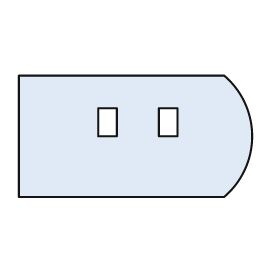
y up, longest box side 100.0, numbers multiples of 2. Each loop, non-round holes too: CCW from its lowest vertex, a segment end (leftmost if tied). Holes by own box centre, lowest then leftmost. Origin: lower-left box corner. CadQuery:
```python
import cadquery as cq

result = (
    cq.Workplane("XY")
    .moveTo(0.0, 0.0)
    .lineTo(88.0, 0.0)
    .threePointArc((100.0, 26.0), (88.0, 52.0))
    .lineTo(0.0, 52.0)
    .close()
    .moveTo(34.0, 26.0)
    .lineTo(42.0, 26.0)
    .lineTo(42.0, 38.0)
    .lineTo(34.0, 38.0)
    .close()
    .moveTo(60.0, 26.0)
    .lineTo(68.0, 26.0)
    .lineTo(68.0, 38.0)
    .lineTo(60.0, 38.0)
    .close()
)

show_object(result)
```